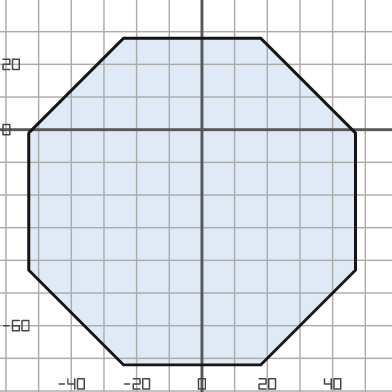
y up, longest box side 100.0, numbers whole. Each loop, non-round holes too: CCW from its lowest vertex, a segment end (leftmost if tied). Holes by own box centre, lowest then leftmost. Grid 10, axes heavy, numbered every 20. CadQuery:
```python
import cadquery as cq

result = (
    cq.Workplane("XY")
    .moveTo(-24.0, -72.0)
    .lineTo(18.0, -72.0)
    .lineTo(47.0, -43.0)
    .lineTo(47.0, -1.0)
    .lineTo(18.0, 28.0)
    .lineTo(-24.0, 28.0)
    .lineTo(-53.0, -1.0)
    .lineTo(-53.0, -43.0)
    .close()
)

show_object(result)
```